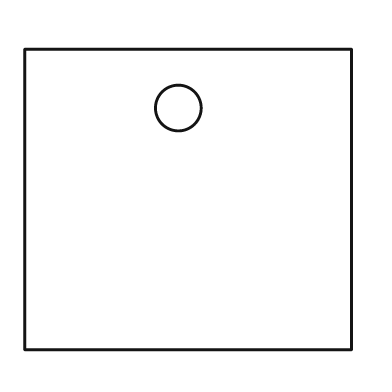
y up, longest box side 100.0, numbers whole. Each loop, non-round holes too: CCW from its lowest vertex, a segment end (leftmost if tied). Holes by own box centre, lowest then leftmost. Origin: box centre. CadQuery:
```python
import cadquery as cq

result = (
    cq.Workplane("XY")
    .moveTo(-50.0, -46.0)
    .lineTo(50.0, -46.0)
    .lineTo(50.0, 46.0)
    .lineTo(-50.0, 46.0)
    .close()
    .moveTo(-3.0, 28.0)
    .circle(7.0)
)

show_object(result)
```